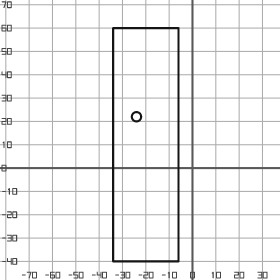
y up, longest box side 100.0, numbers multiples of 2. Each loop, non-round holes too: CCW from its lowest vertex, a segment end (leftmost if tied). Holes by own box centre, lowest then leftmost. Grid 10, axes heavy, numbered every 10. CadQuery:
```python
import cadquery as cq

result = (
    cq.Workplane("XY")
    .moveTo(-34.0, -40.0)
    .lineTo(-6.0, -40.0)
    .lineTo(-6.0, 60.0)
    .lineTo(-34.0, 60.0)
    .close()
    .moveTo(-24.0, 22.0)
    .circle(2.0)
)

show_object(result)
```